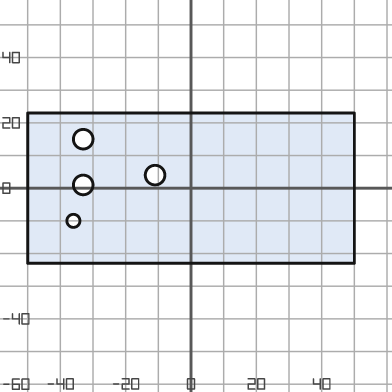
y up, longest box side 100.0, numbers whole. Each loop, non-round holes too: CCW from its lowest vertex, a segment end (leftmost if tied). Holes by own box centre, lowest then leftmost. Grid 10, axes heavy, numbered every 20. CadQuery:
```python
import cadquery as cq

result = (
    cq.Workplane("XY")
    .moveTo(-50.0, -23.0)
    .lineTo(50.0, -23.0)
    .lineTo(50.0, 23.0)
    .lineTo(-50.0, 23.0)
    .close()
    .moveTo(-36.0, -10.0)
    .circle(2.0)
    .moveTo(-33.0, 1.0)
    .circle(3.0)
    .moveTo(-11.0, 4.0)
    .circle(3.0)
    .moveTo(-33.0, 15.0)
    .circle(3.0)
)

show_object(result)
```